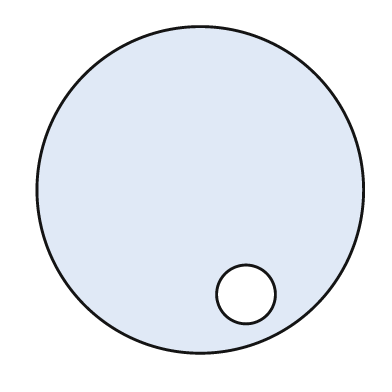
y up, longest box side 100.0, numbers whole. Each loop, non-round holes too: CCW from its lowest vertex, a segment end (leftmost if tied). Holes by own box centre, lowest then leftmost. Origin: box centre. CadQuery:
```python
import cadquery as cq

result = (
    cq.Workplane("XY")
    .moveTo(0.0, 0.0)
    .circle(50.0)
    .moveTo(14.0, -32.0)
    .circle(9.0)
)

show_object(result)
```